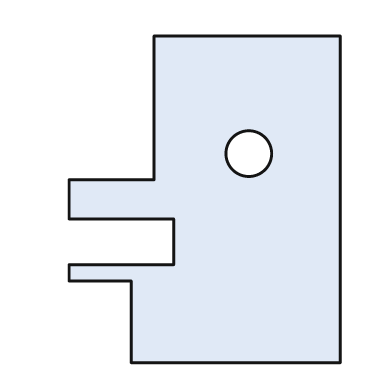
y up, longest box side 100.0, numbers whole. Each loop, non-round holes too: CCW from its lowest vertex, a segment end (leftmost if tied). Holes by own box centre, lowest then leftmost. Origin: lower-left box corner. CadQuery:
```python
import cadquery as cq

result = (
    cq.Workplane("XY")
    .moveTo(19.0, 0.0)
    .lineTo(83.0, 0.0)
    .lineTo(83.0, 100.0)
    .lineTo(26.0, 100.0)
    .lineTo(26.0, 56.0)
    .lineTo(0.0, 56.0)
    .lineTo(0.0, 44.0)
    .lineTo(32.0, 44.0)
    .lineTo(32.0, 30.0)
    .lineTo(0.0, 30.0)
    .lineTo(0.0, 25.0)
    .lineTo(19.0, 25.0)
    .close()
    .moveTo(55.0, 64.0)
    .circle(7.0)
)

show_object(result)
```